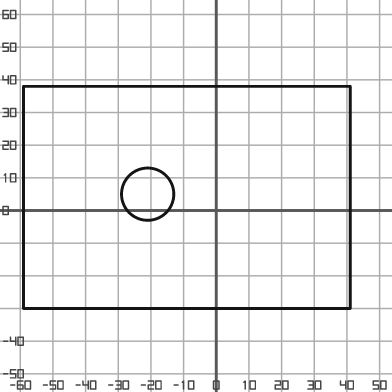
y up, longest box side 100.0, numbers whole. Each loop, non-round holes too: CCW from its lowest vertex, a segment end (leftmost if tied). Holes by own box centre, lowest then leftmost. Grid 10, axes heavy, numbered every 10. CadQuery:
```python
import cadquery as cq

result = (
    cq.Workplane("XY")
    .moveTo(-59.0, -30.0)
    .lineTo(41.0, -30.0)
    .lineTo(41.0, 38.0)
    .lineTo(-59.0, 38.0)
    .close()
    .moveTo(-21.0, 5.0)
    .circle(8.0)
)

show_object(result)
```